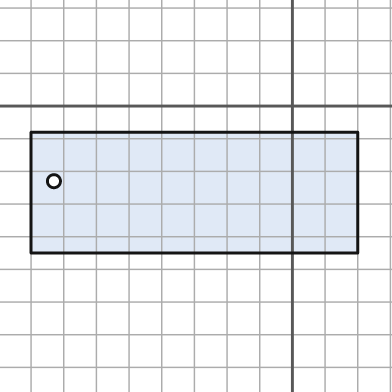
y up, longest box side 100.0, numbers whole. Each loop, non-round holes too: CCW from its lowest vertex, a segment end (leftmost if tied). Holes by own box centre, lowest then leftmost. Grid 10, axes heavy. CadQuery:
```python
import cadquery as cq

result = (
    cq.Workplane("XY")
    .moveTo(-80.0, -45.0)
    .lineTo(20.0, -45.0)
    .lineTo(20.0, -8.0)
    .lineTo(-80.0, -8.0)
    .close()
    .moveTo(-73.0, -23.0)
    .circle(2.0)
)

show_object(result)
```